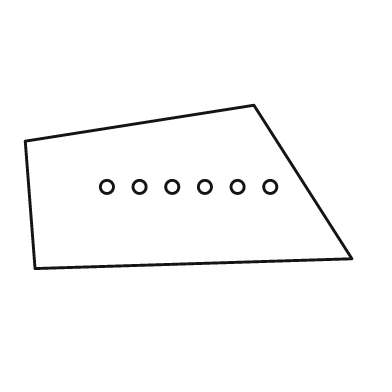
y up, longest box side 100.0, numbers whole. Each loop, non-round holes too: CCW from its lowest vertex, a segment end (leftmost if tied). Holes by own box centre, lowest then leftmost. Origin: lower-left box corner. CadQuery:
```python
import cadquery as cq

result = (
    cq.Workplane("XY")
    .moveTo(3.0, 0.0)
    .lineTo(100.0, 3.0)
    .lineTo(70.0, 50.0)
    .lineTo(0.0, 39.0)
    .close()
    .moveTo(25.0, 25.0)
    .circle(2.0)
    .moveTo(35.0, 25.0)
    .circle(2.0)
    .moveTo(45.0, 25.0)
    .circle(2.0)
    .moveTo(55.0, 25.0)
    .circle(2.0)
    .moveTo(65.0, 25.0)
    .circle(2.0)
    .moveTo(75.0, 25.0)
    .circle(2.0)
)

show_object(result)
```